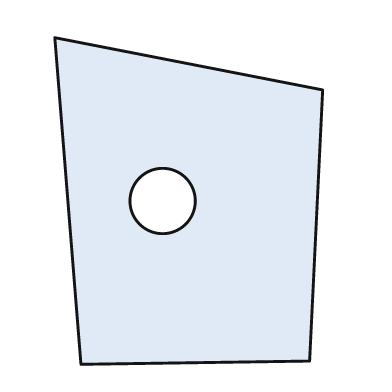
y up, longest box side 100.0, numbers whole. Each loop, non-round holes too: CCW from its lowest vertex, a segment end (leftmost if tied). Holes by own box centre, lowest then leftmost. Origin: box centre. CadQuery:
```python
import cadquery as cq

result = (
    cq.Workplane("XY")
    .moveTo(-33.0, -50.0)
    .lineTo(37.0, -49.0)
    .lineTo(41.0, 34.0)
    .lineTo(-41.0, 50.0)
    .close()
    .moveTo(-8.0, 0.0)
    .circle(10.0)
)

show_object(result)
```